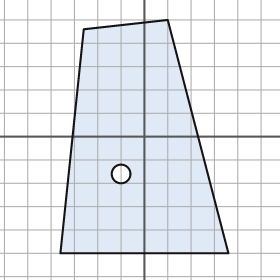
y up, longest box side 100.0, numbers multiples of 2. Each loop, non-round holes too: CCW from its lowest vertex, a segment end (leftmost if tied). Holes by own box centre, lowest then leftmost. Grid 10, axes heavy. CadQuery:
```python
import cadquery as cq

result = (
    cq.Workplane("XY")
    .moveTo(-36.0, -50.0)
    .lineTo(36.0, -50.0)
    .lineTo(10.0, 50.0)
    .lineTo(-26.0, 46.0)
    .close()
    .moveTo(-10.0, -16.0)
    .circle(4.0)
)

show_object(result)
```